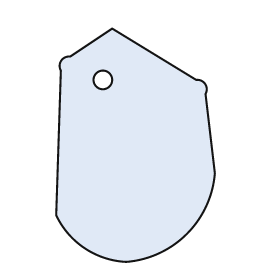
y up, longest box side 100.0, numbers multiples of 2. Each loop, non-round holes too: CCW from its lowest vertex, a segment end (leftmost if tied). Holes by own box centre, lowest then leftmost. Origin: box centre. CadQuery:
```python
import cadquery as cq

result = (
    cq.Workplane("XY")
    .moveTo(-4.0, -50.0)
    .threePointArc((22.0, -38.0), (34.0, -12.0))
    .lineTo(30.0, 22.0)
    .threePointArc((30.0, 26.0), (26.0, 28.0))
    .lineTo(-10.0, 50.0)
    .lineTo(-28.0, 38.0)
    .threePointArc((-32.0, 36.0), (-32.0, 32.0))
    .lineTo(-34.0, -30.0)
    .threePointArc((-22.0, -44.0), (-4.0, -50.0))
    .close()
    .moveTo(-14.0, 28.0)
    .circle(4.0)
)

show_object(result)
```